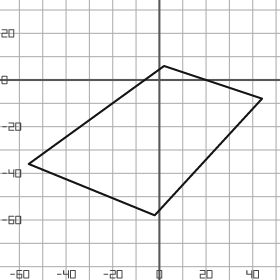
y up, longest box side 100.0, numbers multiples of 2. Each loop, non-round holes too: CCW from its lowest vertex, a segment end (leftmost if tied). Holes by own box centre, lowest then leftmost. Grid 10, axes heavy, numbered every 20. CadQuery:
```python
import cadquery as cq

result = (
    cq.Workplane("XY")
    .moveTo(-2.0, -58.0)
    .lineTo(44.0, -8.0)
    .lineTo(2.0, 6.0)
    .lineTo(-56.0, -36.0)
    .close()
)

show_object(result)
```